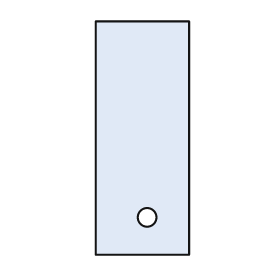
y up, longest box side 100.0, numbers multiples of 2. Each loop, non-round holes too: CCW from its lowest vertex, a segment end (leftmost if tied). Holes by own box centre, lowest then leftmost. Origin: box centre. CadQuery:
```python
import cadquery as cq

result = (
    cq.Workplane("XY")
    .moveTo(-20.0, -50.0)
    .lineTo(20.0, -50.0)
    .lineTo(20.0, 50.0)
    .lineTo(-20.0, 50.0)
    .close()
    .moveTo(2.0, -34.0)
    .circle(4.0)
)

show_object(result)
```